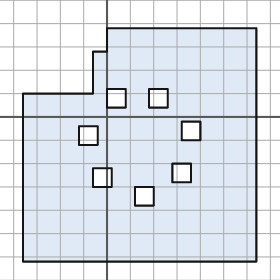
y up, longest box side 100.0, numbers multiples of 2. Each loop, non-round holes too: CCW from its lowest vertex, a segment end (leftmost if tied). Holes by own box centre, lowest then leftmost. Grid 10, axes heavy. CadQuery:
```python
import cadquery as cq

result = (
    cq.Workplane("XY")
    .moveTo(-36.0, -62.0)
    .lineTo(64.0, -62.0)
    .lineTo(64.0, 38.0)
    .lineTo(0.0, 38.0)
    .lineTo(0.0, 28.0)
    .lineTo(-6.0, 28.0)
    .lineTo(-6.0, 10.0)
    .lineTo(-36.0, 10.0)
    .close()
    .moveTo(12.0, -38.0)
    .lineTo(20.0, -38.0)
    .lineTo(20.0, -30.0)
    .lineTo(12.0, -30.0)
    .close()
    .moveTo(-6.0, -30.0)
    .lineTo(2.0, -30.0)
    .lineTo(2.0, -22.0)
    .lineTo(-6.0, -22.0)
    .close()
    .moveTo(28.0, -28.0)
    .lineTo(36.0, -28.0)
    .lineTo(36.0, -20.0)
    .lineTo(28.0, -20.0)
    .close()
    .moveTo(-12.0, -12.0)
    .lineTo(-4.0, -12.0)
    .lineTo(-4.0, -4.0)
    .lineTo(-12.0, -4.0)
    .close()
    .moveTo(32.0, -10.0)
    .lineTo(40.0, -10.0)
    .lineTo(40.0, -2.0)
    .lineTo(32.0, -2.0)
    .close()
    .moveTo(0.0, 4.0)
    .lineTo(8.0, 4.0)
    .lineTo(8.0, 12.0)
    .lineTo(0.0, 12.0)
    .close()
    .moveTo(18.0, 4.0)
    .lineTo(26.0, 4.0)
    .lineTo(26.0, 12.0)
    .lineTo(18.0, 12.0)
    .close()
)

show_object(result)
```